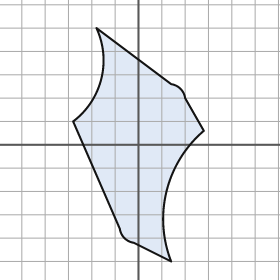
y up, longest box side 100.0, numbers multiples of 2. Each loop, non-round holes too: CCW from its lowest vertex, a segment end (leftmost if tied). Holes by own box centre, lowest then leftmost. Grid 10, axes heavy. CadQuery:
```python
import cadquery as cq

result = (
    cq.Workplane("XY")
    .moveTo(14.0, -50.0)
    .threePointArc((12.0, -20.0), (28.0, 6.0))
    .lineTo(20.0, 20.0)
    .threePointArc((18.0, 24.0), (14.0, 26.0))
    .lineTo(-18.0, 50.0)
    .threePointArc((-16.0, 28.0), (-28.0, 10.0))
    .lineTo(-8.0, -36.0)
    .threePointArc((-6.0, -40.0), (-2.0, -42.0))
    .close()
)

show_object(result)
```